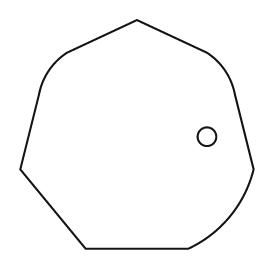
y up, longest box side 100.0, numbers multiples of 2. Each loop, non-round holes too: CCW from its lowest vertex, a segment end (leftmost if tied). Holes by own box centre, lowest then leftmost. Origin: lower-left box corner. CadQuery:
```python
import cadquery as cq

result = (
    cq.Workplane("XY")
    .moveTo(28.0, 0.0)
    .lineTo(72.0, 0.0)
    .threePointArc((90.0, 14.0), (100.0, 34.0))
    .lineTo(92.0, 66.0)
    .threePointArc((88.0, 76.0), (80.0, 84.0))
    .lineTo(50.0, 98.0)
    .lineTo(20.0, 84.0)
    .threePointArc((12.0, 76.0), (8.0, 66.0))
    .lineTo(0.0, 34.0)
    .close()
    .moveTo(80.0, 48.0)
    .circle(4.0)
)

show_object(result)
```